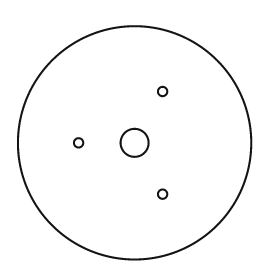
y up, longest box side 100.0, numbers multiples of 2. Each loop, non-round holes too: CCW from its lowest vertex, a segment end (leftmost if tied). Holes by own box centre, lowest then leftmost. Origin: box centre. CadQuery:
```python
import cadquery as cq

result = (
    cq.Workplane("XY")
    .moveTo(0.0, 0.0)
    .circle(50.0)
    .moveTo(12.0, -22.0)
    .circle(2.0)
    .moveTo(-24.0, 0.0)
    .circle(2.0)
    .moveTo(0.0, 0.0)
    .circle(6.0)
    .moveTo(12.0, 22.0)
    .circle(2.0)
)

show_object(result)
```